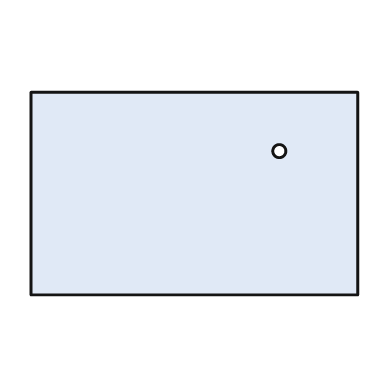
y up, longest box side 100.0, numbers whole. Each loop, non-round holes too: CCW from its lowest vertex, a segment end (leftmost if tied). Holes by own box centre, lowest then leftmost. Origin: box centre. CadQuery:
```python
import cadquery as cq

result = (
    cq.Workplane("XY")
    .moveTo(-50.0, -31.0)
    .lineTo(50.0, -31.0)
    .lineTo(50.0, 31.0)
    .lineTo(-50.0, 31.0)
    .close()
    .moveTo(26.0, 13.0)
    .circle(2.0)
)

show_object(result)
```